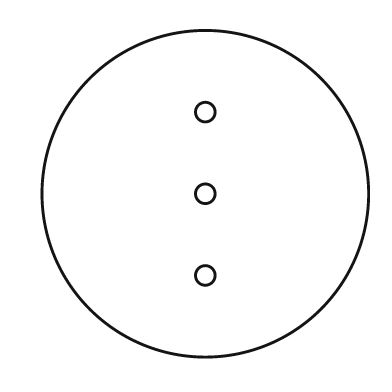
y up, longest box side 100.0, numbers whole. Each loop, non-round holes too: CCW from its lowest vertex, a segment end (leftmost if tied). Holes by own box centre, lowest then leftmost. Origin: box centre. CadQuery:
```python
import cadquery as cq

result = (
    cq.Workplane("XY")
    .moveTo(0.0, 0.0)
    .circle(50.0)
    .moveTo(0.0, -25.0)
    .circle(3.0)
    .moveTo(0.0, 0.0)
    .circle(3.0)
    .moveTo(0.0, 25.0)
    .circle(3.0)
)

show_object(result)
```